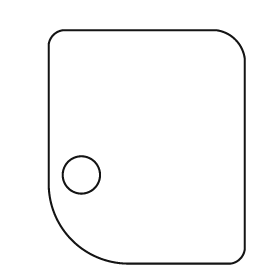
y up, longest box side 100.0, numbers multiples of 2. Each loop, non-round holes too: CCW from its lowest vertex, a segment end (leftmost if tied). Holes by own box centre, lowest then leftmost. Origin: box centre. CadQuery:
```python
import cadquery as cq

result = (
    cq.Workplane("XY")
    .moveTo(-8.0, -50.0)
    .lineTo(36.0, -50.0)
    .threePointArc((40.0, -48.0), (42.0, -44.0))
    .lineTo(42.0, 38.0)
    .threePointArc((38.0, 46.0), (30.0, 50.0))
    .lineTo(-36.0, 50.0)
    .threePointArc((-40.0, 48.0), (-42.0, 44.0))
    .lineTo(-42.0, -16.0)
    .threePointArc((-32.0, -40.0), (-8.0, -50.0))
    .close()
    .moveTo(-28.0, -12.0)
    .circle(8.0)
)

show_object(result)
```